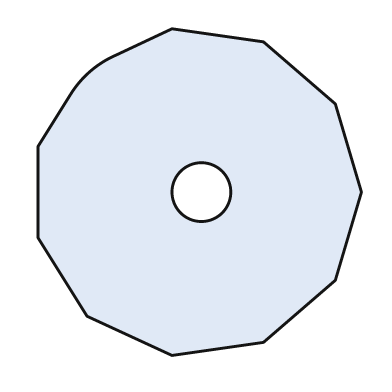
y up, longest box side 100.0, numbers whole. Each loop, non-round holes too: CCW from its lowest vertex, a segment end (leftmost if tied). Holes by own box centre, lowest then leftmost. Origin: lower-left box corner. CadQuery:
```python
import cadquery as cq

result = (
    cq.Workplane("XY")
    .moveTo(41.0, 0.0)
    .lineTo(69.0, 4.0)
    .lineTo(91.0, 23.0)
    .lineTo(99.0, 50.0)
    .lineTo(91.0, 77.0)
    .lineTo(69.0, 96.0)
    .lineTo(41.0, 100.0)
    .lineTo(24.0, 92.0)
    .threePointArc((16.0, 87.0), (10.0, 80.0))
    .lineTo(0.0, 64.0)
    .lineTo(0.0, 36.0)
    .lineTo(15.0, 12.0)
    .close()
    .moveTo(50.0, 50.0)
    .circle(9.0)
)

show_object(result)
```